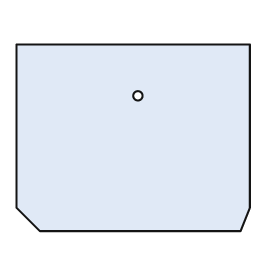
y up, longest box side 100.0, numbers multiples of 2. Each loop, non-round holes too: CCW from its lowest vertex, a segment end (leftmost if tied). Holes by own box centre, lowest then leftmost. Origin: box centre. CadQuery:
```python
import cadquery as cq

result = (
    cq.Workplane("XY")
    .moveTo(-40.0, -40.0)
    .lineTo(46.0, -40.0)
    .lineTo(50.0, -30.0)
    .lineTo(50.0, 40.0)
    .lineTo(-50.0, 40.0)
    .lineTo(-50.0, -30.0)
    .close()
    .moveTo(2.0, 18.0)
    .circle(2.0)
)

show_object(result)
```